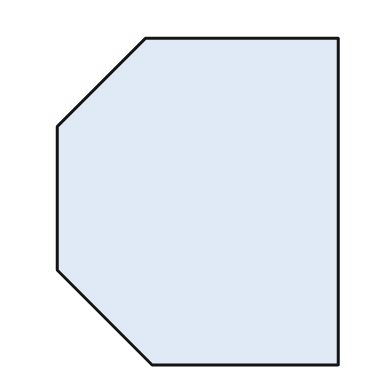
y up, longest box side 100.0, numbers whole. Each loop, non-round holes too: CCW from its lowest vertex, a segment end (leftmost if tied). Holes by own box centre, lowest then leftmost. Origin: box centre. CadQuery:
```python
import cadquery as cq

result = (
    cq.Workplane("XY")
    .moveTo(-14.0, -50.0)
    .lineTo(43.0, -50.0)
    .lineTo(43.0, 50.0)
    .lineTo(-16.0, 50.0)
    .lineTo(-43.0, 23.0)
    .lineTo(-43.0, -21.0)
    .close()
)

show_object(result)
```